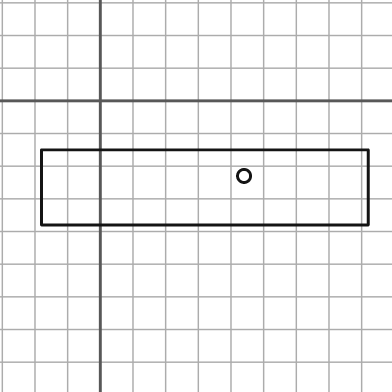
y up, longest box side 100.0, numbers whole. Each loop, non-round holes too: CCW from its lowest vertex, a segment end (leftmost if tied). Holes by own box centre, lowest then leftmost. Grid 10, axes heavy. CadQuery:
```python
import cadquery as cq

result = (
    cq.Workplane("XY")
    .moveTo(-18.0, -38.0)
    .lineTo(82.0, -38.0)
    .lineTo(82.0, -15.0)
    .lineTo(-18.0, -15.0)
    .close()
    .moveTo(44.0, -23.0)
    .circle(2.0)
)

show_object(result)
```